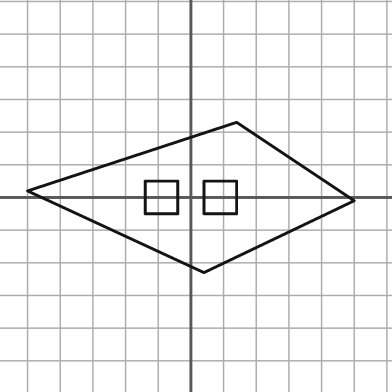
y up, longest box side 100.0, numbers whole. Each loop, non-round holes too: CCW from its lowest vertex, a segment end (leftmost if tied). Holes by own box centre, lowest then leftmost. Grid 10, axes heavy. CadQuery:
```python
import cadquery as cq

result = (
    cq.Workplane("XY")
    .moveTo(4.0, -23.0)
    .lineTo(50.0, -1.0)
    .lineTo(14.0, 23.0)
    .lineTo(-50.0, 2.0)
    .close()
    .moveTo(-14.0, -5.0)
    .lineTo(-4.0, -5.0)
    .lineTo(-4.0, 5.0)
    .lineTo(-14.0, 5.0)
    .close()
    .moveTo(4.0, -5.0)
    .lineTo(14.0, -5.0)
    .lineTo(14.0, 5.0)
    .lineTo(4.0, 5.0)
    .close()
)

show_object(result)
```